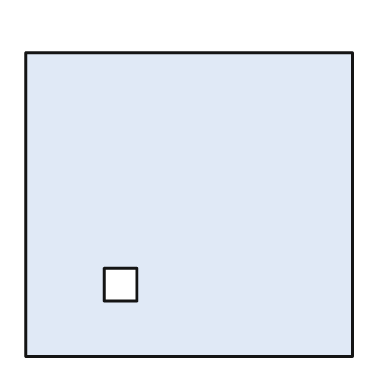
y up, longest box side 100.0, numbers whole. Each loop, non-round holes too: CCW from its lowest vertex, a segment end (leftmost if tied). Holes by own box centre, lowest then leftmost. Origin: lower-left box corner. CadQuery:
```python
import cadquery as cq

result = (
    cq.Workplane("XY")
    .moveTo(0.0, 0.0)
    .lineTo(100.0, 0.0)
    .lineTo(100.0, 93.0)
    .lineTo(0.0, 93.0)
    .close()
    .moveTo(24.0, 17.0)
    .lineTo(34.0, 17.0)
    .lineTo(34.0, 27.0)
    .lineTo(24.0, 27.0)
    .close()
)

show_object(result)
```